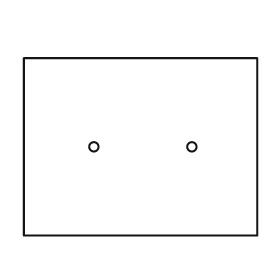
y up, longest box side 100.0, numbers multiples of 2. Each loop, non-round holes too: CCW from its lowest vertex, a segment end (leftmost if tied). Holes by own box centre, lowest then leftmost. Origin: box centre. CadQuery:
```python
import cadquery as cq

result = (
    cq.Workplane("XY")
    .moveTo(-50.0, -38.0)
    .lineTo(50.0, -38.0)
    .lineTo(50.0, 38.0)
    .lineTo(-50.0, 38.0)
    .close()
    .moveTo(-20.0, 0.0)
    .circle(2.0)
    .moveTo(22.0, 0.0)
    .circle(2.0)
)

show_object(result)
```